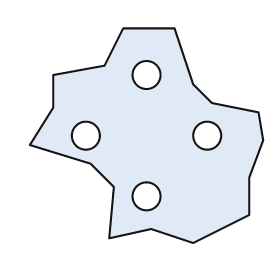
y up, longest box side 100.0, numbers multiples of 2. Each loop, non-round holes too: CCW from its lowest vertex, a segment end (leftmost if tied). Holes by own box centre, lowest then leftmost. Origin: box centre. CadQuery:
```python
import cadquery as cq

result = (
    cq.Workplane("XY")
    .moveTo(20.0, -46.0)
    .lineTo(44.0, -34.0)
    .lineTo(44.0, -18.0)
    .lineTo(50.0, -2.0)
    .lineTo(48.0, 10.0)
    .lineTo(28.0, 14.0)
    .lineTo(20.0, 22.0)
    .lineTo(12.0, 46.0)
    .lineTo(-10.0, 46.0)
    .lineTo(-18.0, 30.0)
    .lineTo(-40.0, 26.0)
    .lineTo(-40.0, 12.0)
    .lineTo(-50.0, -4.0)
    .lineTo(-24.0, -12.0)
    .lineTo(-14.0, -22.0)
    .lineTo(-16.0, -44.0)
    .lineTo(2.0, -40.0)
    .close()
    .moveTo(0.0, -26.0)
    .circle(6.0)
    .moveTo(-26.0, 0.0)
    .circle(6.0)
    .moveTo(26.0, 0.0)
    .circle(6.0)
    .moveTo(0.0, 26.0)
    .circle(6.0)
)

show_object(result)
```